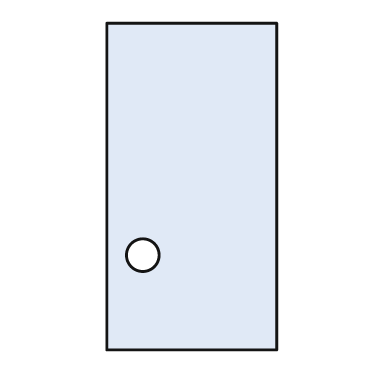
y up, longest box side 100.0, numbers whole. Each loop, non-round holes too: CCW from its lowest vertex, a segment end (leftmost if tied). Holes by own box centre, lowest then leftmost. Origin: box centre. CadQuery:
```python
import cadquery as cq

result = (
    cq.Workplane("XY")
    .moveTo(-26.0, -50.0)
    .lineTo(26.0, -50.0)
    .lineTo(26.0, 50.0)
    .lineTo(-26.0, 50.0)
    .close()
    .moveTo(-15.0, -21.0)
    .circle(5.0)
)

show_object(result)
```